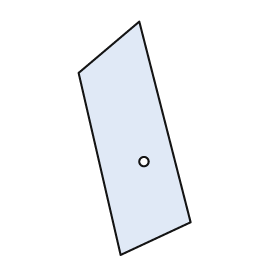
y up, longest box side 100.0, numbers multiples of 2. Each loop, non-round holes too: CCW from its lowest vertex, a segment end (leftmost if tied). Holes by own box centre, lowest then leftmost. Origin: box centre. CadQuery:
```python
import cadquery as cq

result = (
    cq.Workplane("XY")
    .moveTo(-6.0, -50.0)
    .lineTo(24.0, -36.0)
    .lineTo(2.0, 50.0)
    .lineTo(-24.0, 28.0)
    .close()
    .moveTo(4.0, -10.0)
    .circle(2.0)
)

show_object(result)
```